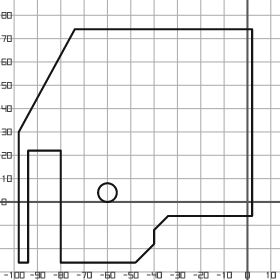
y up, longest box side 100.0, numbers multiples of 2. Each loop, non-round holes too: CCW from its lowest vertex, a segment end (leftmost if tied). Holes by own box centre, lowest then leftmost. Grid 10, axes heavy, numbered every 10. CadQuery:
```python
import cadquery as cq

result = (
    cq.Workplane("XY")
    .moveTo(-98.0, -26.0)
    .lineTo(-94.0, -26.0)
    .lineTo(-94.0, 22.0)
    .lineTo(-80.0, 22.0)
    .lineTo(-80.0, -26.0)
    .lineTo(-48.0, -26.0)
    .lineTo(-40.0, -18.0)
    .lineTo(-40.0, -12.0)
    .lineTo(-34.0, -6.0)
    .lineTo(2.0, -6.0)
    .lineTo(2.0, 74.0)
    .lineTo(-74.0, 74.0)
    .lineTo(-98.0, 30.0)
    .close()
    .moveTo(-60.0, 4.0)
    .circle(4.0)
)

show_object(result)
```